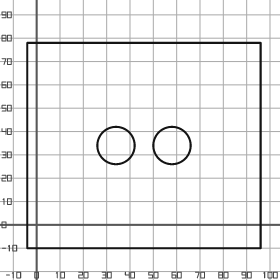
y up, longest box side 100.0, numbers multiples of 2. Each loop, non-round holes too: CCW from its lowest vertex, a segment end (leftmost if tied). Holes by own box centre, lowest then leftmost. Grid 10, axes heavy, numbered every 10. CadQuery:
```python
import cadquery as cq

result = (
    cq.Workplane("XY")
    .moveTo(-4.0, -10.0)
    .lineTo(96.0, -10.0)
    .lineTo(96.0, 78.0)
    .lineTo(-4.0, 78.0)
    .close()
    .moveTo(34.0, 34.0)
    .circle(8.0)
    .moveTo(58.0, 34.0)
    .circle(8.0)
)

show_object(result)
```